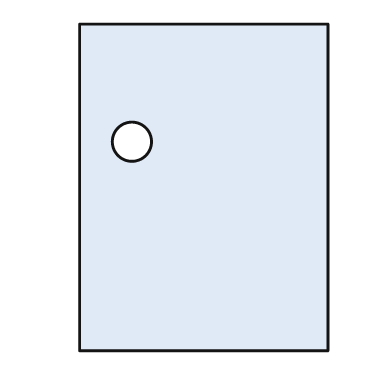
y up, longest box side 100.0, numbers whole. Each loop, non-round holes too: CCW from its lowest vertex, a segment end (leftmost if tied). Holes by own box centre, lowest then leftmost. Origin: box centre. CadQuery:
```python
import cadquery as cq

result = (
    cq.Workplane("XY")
    .moveTo(-38.0, -50.0)
    .lineTo(38.0, -50.0)
    .lineTo(38.0, 50.0)
    .lineTo(-38.0, 50.0)
    .close()
    .moveTo(-22.0, 14.0)
    .circle(6.0)
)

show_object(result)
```